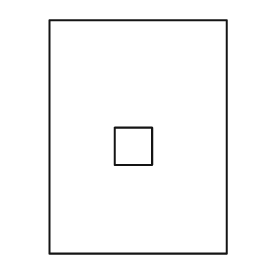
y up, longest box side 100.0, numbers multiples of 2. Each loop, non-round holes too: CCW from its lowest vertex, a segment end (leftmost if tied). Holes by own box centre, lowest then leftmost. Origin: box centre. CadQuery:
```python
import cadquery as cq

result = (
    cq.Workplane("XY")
    .moveTo(-38.0, -50.0)
    .lineTo(38.0, -50.0)
    .lineTo(38.0, 50.0)
    .lineTo(-38.0, 50.0)
    .close()
    .moveTo(-10.0, -12.0)
    .lineTo(6.0, -12.0)
    .lineTo(6.0, 4.0)
    .lineTo(-10.0, 4.0)
    .close()
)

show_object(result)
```